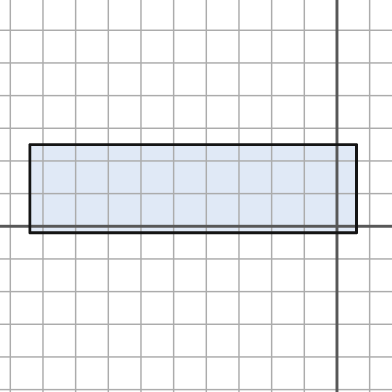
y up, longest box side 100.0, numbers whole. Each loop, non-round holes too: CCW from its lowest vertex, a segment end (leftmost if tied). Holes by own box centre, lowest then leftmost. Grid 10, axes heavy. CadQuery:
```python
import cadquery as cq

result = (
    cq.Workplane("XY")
    .moveTo(-94.0, -2.0)
    .lineTo(6.0, -2.0)
    .lineTo(6.0, 25.0)
    .lineTo(-94.0, 25.0)
    .close()
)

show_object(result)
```